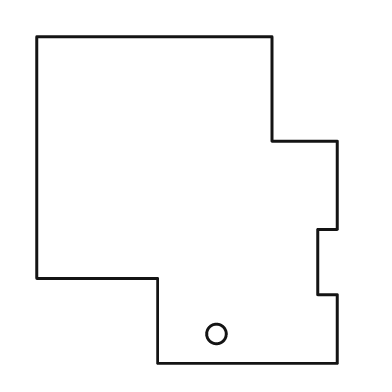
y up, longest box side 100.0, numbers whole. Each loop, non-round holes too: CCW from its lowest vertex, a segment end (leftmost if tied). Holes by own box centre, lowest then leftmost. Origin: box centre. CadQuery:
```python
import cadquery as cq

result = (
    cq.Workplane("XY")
    .moveTo(-9.0, -50.0)
    .lineTo(46.0, -50.0)
    .lineTo(46.0, -29.0)
    .lineTo(40.0, -29.0)
    .lineTo(40.0, -9.0)
    .lineTo(46.0, -9.0)
    .lineTo(46.0, 18.0)
    .lineTo(26.0, 18.0)
    .lineTo(26.0, 50.0)
    .lineTo(-46.0, 50.0)
    .lineTo(-46.0, -24.0)
    .lineTo(-9.0, -24.0)
    .close()
    .moveTo(9.0, -41.0)
    .circle(3.0)
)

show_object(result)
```